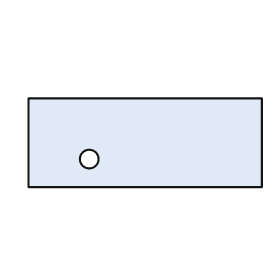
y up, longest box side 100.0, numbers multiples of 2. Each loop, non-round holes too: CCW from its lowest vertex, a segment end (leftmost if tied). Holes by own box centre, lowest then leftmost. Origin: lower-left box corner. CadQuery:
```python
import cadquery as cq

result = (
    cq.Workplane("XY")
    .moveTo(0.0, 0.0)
    .lineTo(100.0, 0.0)
    .lineTo(100.0, 38.0)
    .lineTo(0.0, 38.0)
    .close()
    .moveTo(26.0, 12.0)
    .circle(4.0)
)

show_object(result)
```